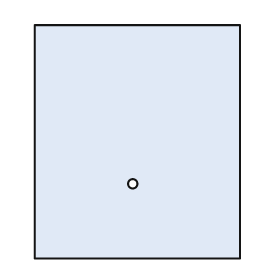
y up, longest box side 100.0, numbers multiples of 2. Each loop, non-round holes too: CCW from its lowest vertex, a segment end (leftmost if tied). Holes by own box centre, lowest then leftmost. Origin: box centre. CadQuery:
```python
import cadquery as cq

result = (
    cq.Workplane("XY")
    .moveTo(-44.0, -50.0)
    .lineTo(44.0, -50.0)
    .lineTo(44.0, 50.0)
    .lineTo(-44.0, 50.0)
    .close()
    .moveTo(-2.0, -18.0)
    .circle(2.0)
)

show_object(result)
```